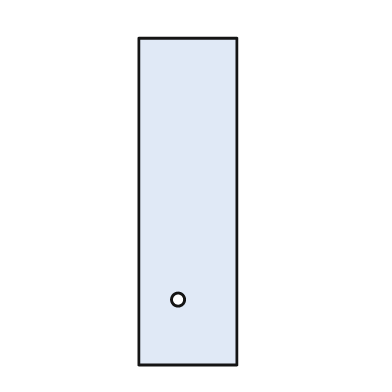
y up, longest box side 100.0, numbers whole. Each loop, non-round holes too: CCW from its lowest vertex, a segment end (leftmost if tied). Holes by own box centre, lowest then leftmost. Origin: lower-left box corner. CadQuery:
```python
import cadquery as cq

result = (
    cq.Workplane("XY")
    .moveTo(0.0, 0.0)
    .lineTo(30.0, 0.0)
    .lineTo(30.0, 100.0)
    .lineTo(0.0, 100.0)
    .close()
    .moveTo(12.0, 20.0)
    .circle(2.0)
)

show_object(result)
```